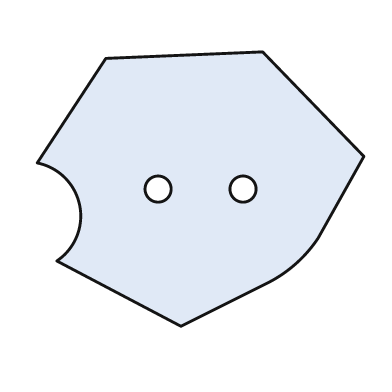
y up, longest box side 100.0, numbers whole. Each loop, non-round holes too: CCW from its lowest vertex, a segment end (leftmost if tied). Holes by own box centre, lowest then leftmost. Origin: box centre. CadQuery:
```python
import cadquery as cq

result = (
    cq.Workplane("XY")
    .moveTo(-6.0, -42.0)
    .lineTo(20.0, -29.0)
    .threePointArc((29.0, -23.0), (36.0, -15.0))
    .lineTo(50.0, 10.0)
    .lineTo(19.0, 42.0)
    .lineTo(-29.0, 40.0)
    .lineTo(-50.0, 8.0)
    .threePointArc((-37.0, -5.0), (-44.0, -22.0))
    .close()
    .moveTo(-13.0, 0.0)
    .circle(4.0)
    .moveTo(13.0, 0.0)
    .circle(4.0)
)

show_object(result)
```